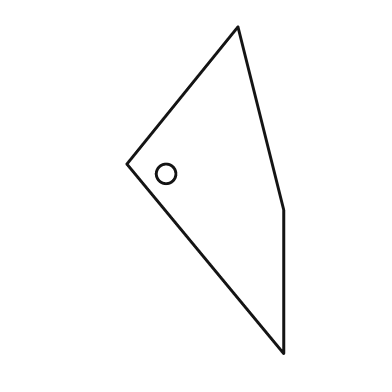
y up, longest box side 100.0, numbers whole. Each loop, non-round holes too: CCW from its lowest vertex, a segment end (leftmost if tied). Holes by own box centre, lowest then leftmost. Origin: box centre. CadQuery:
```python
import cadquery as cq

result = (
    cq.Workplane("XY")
    .moveTo(24.0, -50.0)
    .lineTo(24.0, -6.0)
    .lineTo(10.0, 50.0)
    .lineTo(-24.0, 8.0)
    .close()
    .moveTo(-12.0, 5.0)
    .circle(3.0)
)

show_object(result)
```